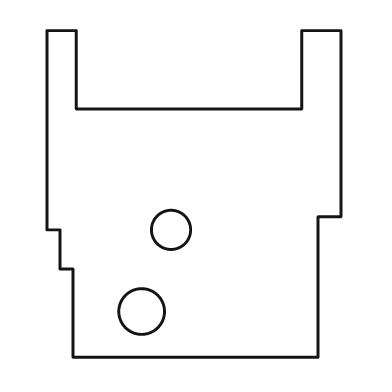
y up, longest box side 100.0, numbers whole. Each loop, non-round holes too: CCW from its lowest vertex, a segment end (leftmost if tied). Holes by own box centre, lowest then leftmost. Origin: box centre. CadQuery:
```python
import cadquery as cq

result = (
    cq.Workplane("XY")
    .moveTo(-37.0, -50.0)
    .lineTo(38.0, -50.0)
    .lineTo(38.0, -7.0)
    .lineTo(45.0, -7.0)
    .lineTo(45.0, 50.0)
    .lineTo(33.0, 50.0)
    .lineTo(33.0, 26.0)
    .lineTo(-36.0, 26.0)
    .lineTo(-36.0, 50.0)
    .lineTo(-45.0, 50.0)
    .lineTo(-45.0, -11.0)
    .lineTo(-41.0, -11.0)
    .lineTo(-41.0, -23.0)
    .lineTo(-37.0, -23.0)
    .close()
    .moveTo(-16.0, -36.0)
    .circle(7.0)
    .moveTo(-7.0, -11.0)
    .circle(6.0)
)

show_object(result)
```